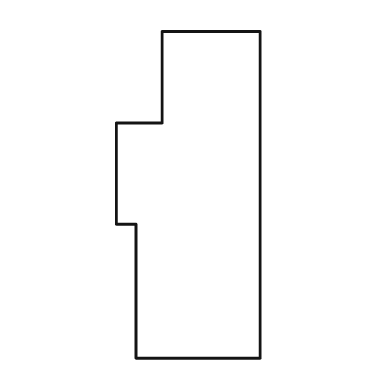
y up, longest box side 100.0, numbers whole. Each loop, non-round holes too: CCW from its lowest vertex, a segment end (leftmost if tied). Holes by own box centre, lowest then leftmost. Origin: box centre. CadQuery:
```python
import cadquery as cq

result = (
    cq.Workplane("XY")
    .moveTo(-16.0, -50.0)
    .lineTo(22.0, -50.0)
    .lineTo(22.0, 50.0)
    .lineTo(-8.0, 50.0)
    .lineTo(-8.0, 22.0)
    .lineTo(-22.0, 22.0)
    .lineTo(-22.0, -9.0)
    .lineTo(-16.0, -9.0)
    .close()
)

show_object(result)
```